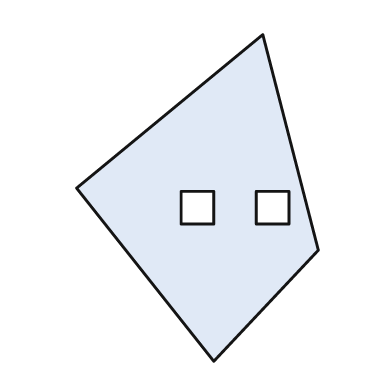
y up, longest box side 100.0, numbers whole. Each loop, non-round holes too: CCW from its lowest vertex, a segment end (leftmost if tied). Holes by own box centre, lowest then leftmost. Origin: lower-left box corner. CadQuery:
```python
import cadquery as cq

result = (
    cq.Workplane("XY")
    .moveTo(42.0, 0.0)
    .lineTo(74.0, 34.0)
    .lineTo(57.0, 100.0)
    .lineTo(0.0, 53.0)
    .close()
    .moveTo(32.0, 42.0)
    .lineTo(42.0, 42.0)
    .lineTo(42.0, 52.0)
    .lineTo(32.0, 52.0)
    .close()
    .moveTo(55.0, 42.0)
    .lineTo(65.0, 42.0)
    .lineTo(65.0, 52.0)
    .lineTo(55.0, 52.0)
    .close()
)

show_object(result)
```